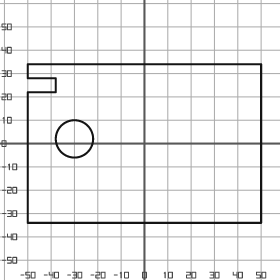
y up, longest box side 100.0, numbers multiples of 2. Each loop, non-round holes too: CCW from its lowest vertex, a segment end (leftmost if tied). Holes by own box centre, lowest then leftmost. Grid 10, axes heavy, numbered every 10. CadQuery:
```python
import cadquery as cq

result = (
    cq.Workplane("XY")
    .moveTo(-50.0, -34.0)
    .lineTo(50.0, -34.0)
    .lineTo(50.0, 34.0)
    .lineTo(-50.0, 34.0)
    .lineTo(-50.0, 28.0)
    .lineTo(-38.0, 28.0)
    .lineTo(-38.0, 22.0)
    .lineTo(-50.0, 22.0)
    .close()
    .moveTo(-30.0, 2.0)
    .circle(8.0)
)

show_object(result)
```